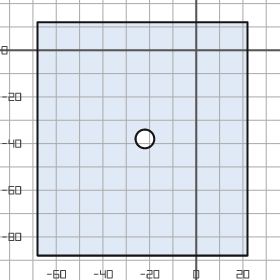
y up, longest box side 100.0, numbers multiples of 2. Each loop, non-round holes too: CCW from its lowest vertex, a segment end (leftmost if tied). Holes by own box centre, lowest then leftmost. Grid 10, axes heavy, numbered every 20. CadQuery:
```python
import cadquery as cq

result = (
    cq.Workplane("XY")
    .moveTo(-68.0, -88.0)
    .lineTo(22.0, -88.0)
    .lineTo(22.0, 12.0)
    .lineTo(-68.0, 12.0)
    .close()
    .moveTo(-22.0, -38.0)
    .circle(4.0)
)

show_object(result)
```